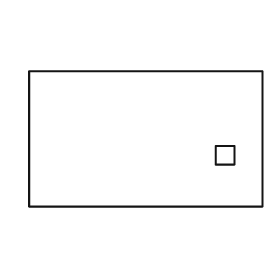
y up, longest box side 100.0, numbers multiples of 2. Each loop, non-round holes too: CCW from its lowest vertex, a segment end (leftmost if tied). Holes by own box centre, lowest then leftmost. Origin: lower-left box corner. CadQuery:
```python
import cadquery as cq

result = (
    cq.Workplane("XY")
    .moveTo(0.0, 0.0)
    .lineTo(100.0, 0.0)
    .lineTo(100.0, 58.0)
    .lineTo(0.0, 58.0)
    .close()
    .moveTo(80.0, 18.0)
    .lineTo(88.0, 18.0)
    .lineTo(88.0, 26.0)
    .lineTo(80.0, 26.0)
    .close()
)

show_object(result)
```